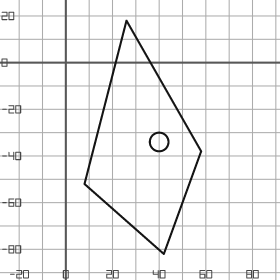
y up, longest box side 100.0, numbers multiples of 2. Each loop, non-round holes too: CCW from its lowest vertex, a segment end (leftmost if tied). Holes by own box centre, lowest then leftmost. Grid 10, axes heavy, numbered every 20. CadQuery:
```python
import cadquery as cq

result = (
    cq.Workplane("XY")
    .moveTo(42.0, -82.0)
    .lineTo(58.0, -38.0)
    .lineTo(26.0, 18.0)
    .lineTo(8.0, -52.0)
    .close()
    .moveTo(40.0, -34.0)
    .circle(4.0)
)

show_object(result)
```